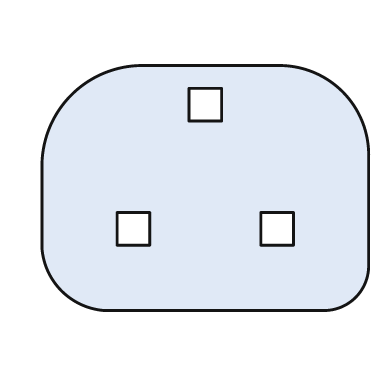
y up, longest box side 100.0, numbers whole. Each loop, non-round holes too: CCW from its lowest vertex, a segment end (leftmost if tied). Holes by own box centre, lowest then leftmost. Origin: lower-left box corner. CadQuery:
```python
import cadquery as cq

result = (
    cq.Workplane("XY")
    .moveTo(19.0, 0.0)
    .lineTo(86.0, 0.0)
    .threePointArc((96.0, 4.0), (100.0, 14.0))
    .lineTo(100.0, 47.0)
    .threePointArc((92.0, 67.0), (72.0, 75.0))
    .lineTo(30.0, 75.0)
    .threePointArc((9.0, 66.0), (0.0, 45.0))
    .lineTo(0.0, 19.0)
    .threePointArc((6.0, 6.0), (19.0, 0.0))
    .close()
    .moveTo(23.0, 20.0)
    .lineTo(33.0, 20.0)
    .lineTo(33.0, 30.0)
    .lineTo(23.0, 30.0)
    .close()
    .moveTo(67.0, 20.0)
    .lineTo(77.0, 20.0)
    .lineTo(77.0, 30.0)
    .lineTo(67.0, 30.0)
    .close()
    .moveTo(45.0, 58.0)
    .lineTo(55.0, 58.0)
    .lineTo(55.0, 68.0)
    .lineTo(45.0, 68.0)
    .close()
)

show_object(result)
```